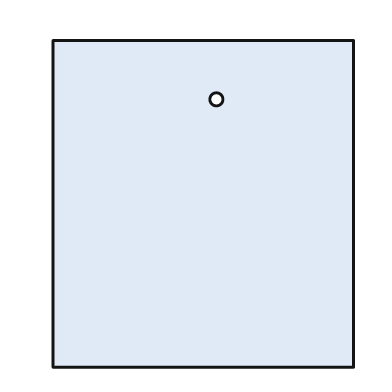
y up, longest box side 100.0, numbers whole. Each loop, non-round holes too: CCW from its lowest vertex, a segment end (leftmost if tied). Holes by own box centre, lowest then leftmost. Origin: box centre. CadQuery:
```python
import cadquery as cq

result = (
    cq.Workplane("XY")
    .moveTo(-46.0, -50.0)
    .lineTo(46.0, -50.0)
    .lineTo(46.0, 50.0)
    .lineTo(-46.0, 50.0)
    .close()
    .moveTo(4.0, 32.0)
    .circle(2.0)
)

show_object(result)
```